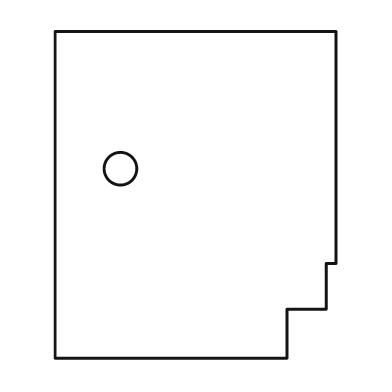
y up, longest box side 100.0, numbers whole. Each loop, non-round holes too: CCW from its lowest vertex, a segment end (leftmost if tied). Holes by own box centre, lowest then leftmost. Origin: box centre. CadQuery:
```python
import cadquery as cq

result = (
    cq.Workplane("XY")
    .moveTo(-43.0, -50.0)
    .lineTo(28.0, -50.0)
    .lineTo(28.0, -35.0)
    .lineTo(40.0, -35.0)
    .lineTo(40.0, -21.0)
    .lineTo(43.0, -21.0)
    .lineTo(43.0, 50.0)
    .lineTo(-43.0, 50.0)
    .close()
    .moveTo(-23.0, 8.0)
    .circle(5.0)
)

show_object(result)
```